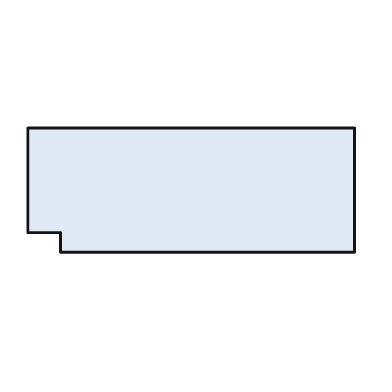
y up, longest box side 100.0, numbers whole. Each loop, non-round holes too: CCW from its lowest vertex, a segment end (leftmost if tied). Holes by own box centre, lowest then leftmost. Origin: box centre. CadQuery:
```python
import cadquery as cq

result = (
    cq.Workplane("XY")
    .moveTo(-40.0, -19.0)
    .lineTo(50.0, -19.0)
    .lineTo(50.0, 19.0)
    .lineTo(-50.0, 19.0)
    .lineTo(-50.0, -13.0)
    .lineTo(-40.0, -13.0)
    .close()
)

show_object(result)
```